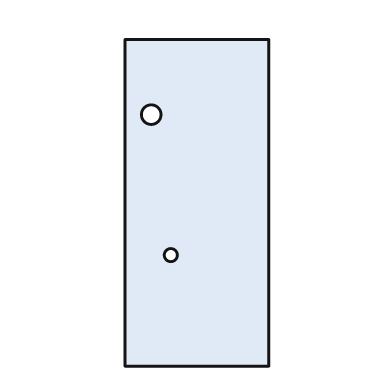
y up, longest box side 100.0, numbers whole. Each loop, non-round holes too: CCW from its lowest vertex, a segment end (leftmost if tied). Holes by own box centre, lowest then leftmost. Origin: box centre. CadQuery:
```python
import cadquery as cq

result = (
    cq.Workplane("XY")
    .moveTo(-22.0, -50.0)
    .lineTo(22.0, -50.0)
    .lineTo(22.0, 50.0)
    .lineTo(-22.0, 50.0)
    .close()
    .moveTo(-8.0, -16.0)
    .circle(2.0)
    .moveTo(-14.0, 27.0)
    .circle(3.0)
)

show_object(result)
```